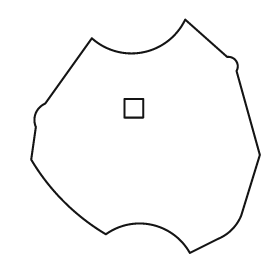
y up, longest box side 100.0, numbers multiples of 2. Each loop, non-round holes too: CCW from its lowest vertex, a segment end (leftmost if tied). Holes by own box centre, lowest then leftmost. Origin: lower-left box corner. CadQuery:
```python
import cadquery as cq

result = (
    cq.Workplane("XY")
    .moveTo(68.0, 0.0)
    .lineTo(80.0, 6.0)
    .threePointArc((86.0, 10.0), (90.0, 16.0))
    .lineTo(98.0, 42.0)
    .lineTo(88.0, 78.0)
    .threePointArc((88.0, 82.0), (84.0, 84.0))
    .lineTo(66.0, 100.0)
    .threePointArc((48.0, 86.0), (26.0, 92.0))
    .lineTo(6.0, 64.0)
    .threePointArc((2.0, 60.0), (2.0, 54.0))
    .lineTo(0.0, 40.0)
    .threePointArc((14.0, 22.0), (32.0, 8.0))
    .threePointArc((52.0, 12.0), (68.0, 0.0))
    .close()
    .moveTo(40.0, 58.0)
    .lineTo(48.0, 58.0)
    .lineTo(48.0, 66.0)
    .lineTo(40.0, 66.0)
    .close()
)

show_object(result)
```